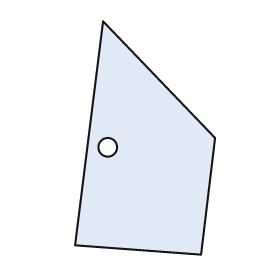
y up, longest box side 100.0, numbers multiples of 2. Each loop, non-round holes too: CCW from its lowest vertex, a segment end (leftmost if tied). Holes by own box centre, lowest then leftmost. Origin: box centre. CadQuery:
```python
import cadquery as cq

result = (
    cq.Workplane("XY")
    .moveTo(24.0, -50.0)
    .lineTo(30.0, 0.0)
    .lineTo(-18.0, 50.0)
    .lineTo(-30.0, -46.0)
    .close()
    .moveTo(-16.0, -4.0)
    .circle(4.0)
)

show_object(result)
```